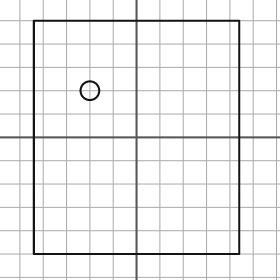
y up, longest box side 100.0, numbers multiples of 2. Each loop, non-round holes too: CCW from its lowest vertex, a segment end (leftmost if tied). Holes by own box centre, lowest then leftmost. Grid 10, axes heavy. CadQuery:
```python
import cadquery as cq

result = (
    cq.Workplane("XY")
    .moveTo(-44.0, -50.0)
    .lineTo(44.0, -50.0)
    .lineTo(44.0, 50.0)
    .lineTo(-44.0, 50.0)
    .close()
    .moveTo(-20.0, 20.0)
    .circle(4.0)
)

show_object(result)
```